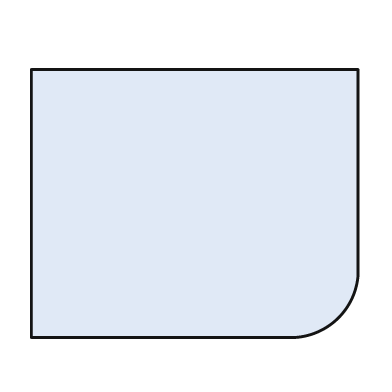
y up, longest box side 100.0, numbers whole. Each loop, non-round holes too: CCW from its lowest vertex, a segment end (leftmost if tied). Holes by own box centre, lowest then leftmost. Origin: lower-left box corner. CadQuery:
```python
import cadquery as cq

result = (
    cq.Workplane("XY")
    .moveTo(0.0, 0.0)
    .lineTo(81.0, 0.0)
    .threePointArc((94.0, 6.0), (100.0, 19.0))
    .lineTo(100.0, 82.0)
    .lineTo(0.0, 82.0)
    .close()
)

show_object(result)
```